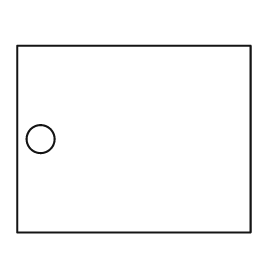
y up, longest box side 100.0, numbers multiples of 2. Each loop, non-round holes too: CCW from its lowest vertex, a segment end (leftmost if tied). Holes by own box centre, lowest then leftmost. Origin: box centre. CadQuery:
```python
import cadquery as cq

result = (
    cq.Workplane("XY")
    .moveTo(-50.0, -40.0)
    .lineTo(50.0, -40.0)
    .lineTo(50.0, 40.0)
    .lineTo(-50.0, 40.0)
    .close()
    .moveTo(-40.0, 0.0)
    .circle(6.0)
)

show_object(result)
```